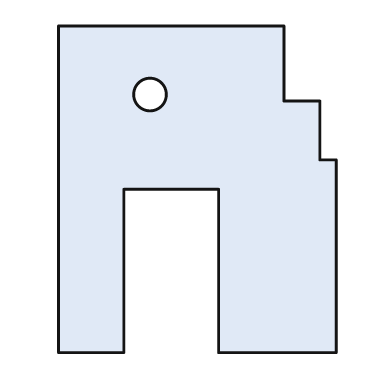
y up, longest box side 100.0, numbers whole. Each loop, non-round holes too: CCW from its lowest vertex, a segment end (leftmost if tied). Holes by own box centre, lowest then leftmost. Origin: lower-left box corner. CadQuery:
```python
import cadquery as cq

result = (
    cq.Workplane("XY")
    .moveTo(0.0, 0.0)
    .lineTo(20.0, 0.0)
    .lineTo(20.0, 50.0)
    .lineTo(49.0, 50.0)
    .lineTo(49.0, 0.0)
    .lineTo(85.0, 0.0)
    .lineTo(85.0, 59.0)
    .lineTo(80.0, 59.0)
    .lineTo(80.0, 77.0)
    .lineTo(69.0, 77.0)
    .lineTo(69.0, 100.0)
    .lineTo(0.0, 100.0)
    .close()
    .moveTo(28.0, 79.0)
    .circle(5.0)
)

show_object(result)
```